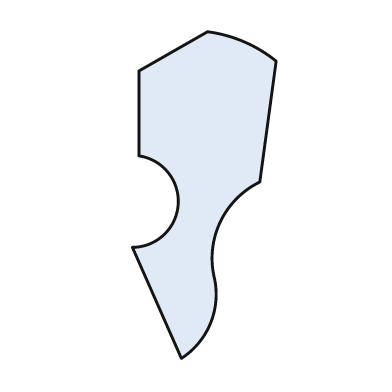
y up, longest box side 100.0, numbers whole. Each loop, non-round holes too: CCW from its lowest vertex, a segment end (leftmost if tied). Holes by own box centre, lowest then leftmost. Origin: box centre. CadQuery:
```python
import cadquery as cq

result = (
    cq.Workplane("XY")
    .moveTo(-7.0, -50.0)
    .threePointArc((2.0, -39.0), (3.0, -25.0))
    .threePointArc((5.0, -8.0), (17.0, 4.0))
    .lineTo(22.0, 41.0)
    .threePointArc((12.0, 47.0), (1.0, 50.0))
    .lineTo(-20.0, 38.0)
    .lineTo(-20.0, 12.0)
    .threePointArc((-8.0, -3.0), (-22.0, -16.0))
    .close()
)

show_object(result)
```